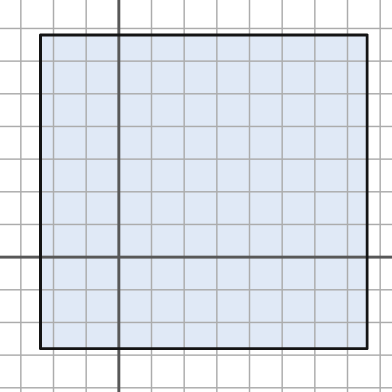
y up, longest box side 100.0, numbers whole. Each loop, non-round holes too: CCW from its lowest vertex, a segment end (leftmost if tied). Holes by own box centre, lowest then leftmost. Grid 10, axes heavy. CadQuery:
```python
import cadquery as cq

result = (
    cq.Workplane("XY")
    .moveTo(-24.0, -28.0)
    .lineTo(76.0, -28.0)
    .lineTo(76.0, 68.0)
    .lineTo(-24.0, 68.0)
    .close()
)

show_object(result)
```